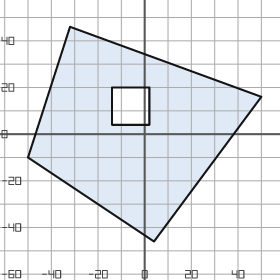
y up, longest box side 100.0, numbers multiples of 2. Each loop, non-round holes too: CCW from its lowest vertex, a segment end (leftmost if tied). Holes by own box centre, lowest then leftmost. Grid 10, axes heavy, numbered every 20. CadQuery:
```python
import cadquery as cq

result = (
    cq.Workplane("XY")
    .moveTo(4.0, -46.0)
    .lineTo(50.0, 16.0)
    .lineTo(-32.0, 46.0)
    .lineTo(-50.0, -10.0)
    .close()
    .moveTo(-14.0, 4.0)
    .lineTo(2.0, 4.0)
    .lineTo(2.0, 20.0)
    .lineTo(-14.0, 20.0)
    .close()
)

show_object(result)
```